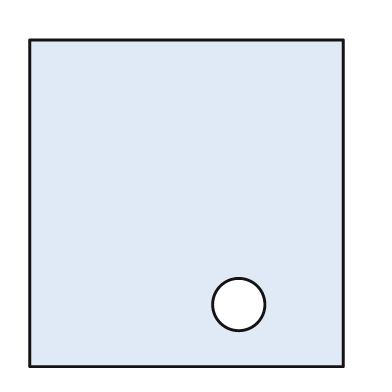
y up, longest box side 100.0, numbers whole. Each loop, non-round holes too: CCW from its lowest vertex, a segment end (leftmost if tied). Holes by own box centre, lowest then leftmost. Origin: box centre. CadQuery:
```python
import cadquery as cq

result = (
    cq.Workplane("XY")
    .moveTo(-48.0, -50.0)
    .lineTo(48.0, -50.0)
    .lineTo(48.0, 50.0)
    .lineTo(-48.0, 50.0)
    .close()
    .moveTo(16.0, -31.0)
    .circle(8.0)
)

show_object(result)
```